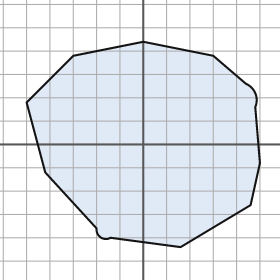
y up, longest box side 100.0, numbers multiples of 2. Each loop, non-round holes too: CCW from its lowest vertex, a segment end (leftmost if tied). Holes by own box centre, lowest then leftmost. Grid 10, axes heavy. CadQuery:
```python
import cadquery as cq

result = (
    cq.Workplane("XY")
    .moveTo(16.0, -44.0)
    .lineTo(46.0, -26.0)
    .lineTo(50.0, -8.0)
    .lineTo(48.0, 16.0)
    .threePointArc((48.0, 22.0), (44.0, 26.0))
    .lineTo(30.0, 38.0)
    .lineTo(0.0, 44.0)
    .lineTo(-30.0, 38.0)
    .lineTo(-50.0, 18.0)
    .lineTo(-42.0, -12.0)
    .lineTo(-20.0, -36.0)
    .threePointArc((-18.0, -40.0), (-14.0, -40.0))
    .close()
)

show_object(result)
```